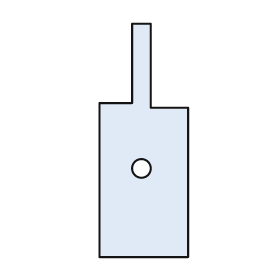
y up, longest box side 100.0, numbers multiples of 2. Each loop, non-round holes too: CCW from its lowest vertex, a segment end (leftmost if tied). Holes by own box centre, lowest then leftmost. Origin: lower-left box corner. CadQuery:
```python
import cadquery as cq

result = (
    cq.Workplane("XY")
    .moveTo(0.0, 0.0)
    .lineTo(38.0, 0.0)
    .lineTo(38.0, 64.0)
    .lineTo(22.0, 64.0)
    .lineTo(22.0, 100.0)
    .lineTo(14.0, 100.0)
    .lineTo(14.0, 66.0)
    .lineTo(0.0, 66.0)
    .close()
    .moveTo(18.0, 38.0)
    .circle(4.0)
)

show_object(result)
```